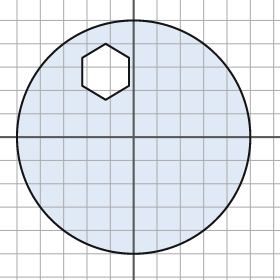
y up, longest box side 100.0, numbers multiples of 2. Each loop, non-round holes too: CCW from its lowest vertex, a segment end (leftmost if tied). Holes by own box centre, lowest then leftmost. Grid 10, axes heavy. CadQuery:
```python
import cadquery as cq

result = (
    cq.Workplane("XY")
    .moveTo(0.0, 0.0)
    .circle(50.0)
    .moveTo(-12.0, 16.0)
    .lineTo(-2.0, 22.0)
    .lineTo(-2.0, 34.0)
    .lineTo(-12.0, 40.0)
    .lineTo(-22.0, 34.0)
    .lineTo(-22.0, 22.0)
    .close()
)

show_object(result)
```